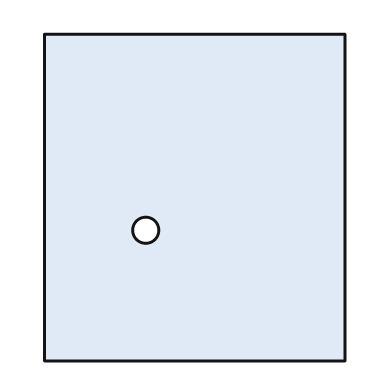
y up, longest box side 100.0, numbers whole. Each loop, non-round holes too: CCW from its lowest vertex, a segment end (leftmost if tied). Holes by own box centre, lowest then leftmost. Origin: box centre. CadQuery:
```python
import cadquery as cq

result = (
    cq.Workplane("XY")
    .moveTo(-46.0, -50.0)
    .lineTo(46.0, -50.0)
    .lineTo(46.0, 50.0)
    .lineTo(-46.0, 50.0)
    .close()
    .moveTo(-15.0, -10.0)
    .circle(4.0)
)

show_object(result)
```